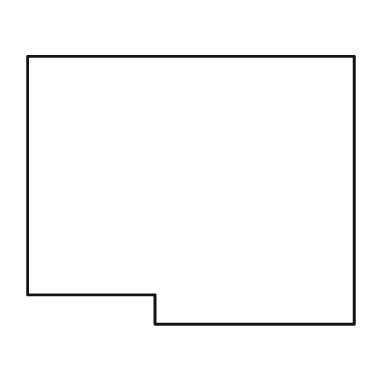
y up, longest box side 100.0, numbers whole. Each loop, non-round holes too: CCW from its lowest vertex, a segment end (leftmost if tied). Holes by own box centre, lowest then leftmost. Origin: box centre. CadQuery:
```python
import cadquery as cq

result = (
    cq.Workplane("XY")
    .moveTo(-11.0, -41.0)
    .lineTo(50.0, -41.0)
    .lineTo(50.0, 41.0)
    .lineTo(-50.0, 41.0)
    .lineTo(-50.0, -32.0)
    .lineTo(-11.0, -32.0)
    .close()
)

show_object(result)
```